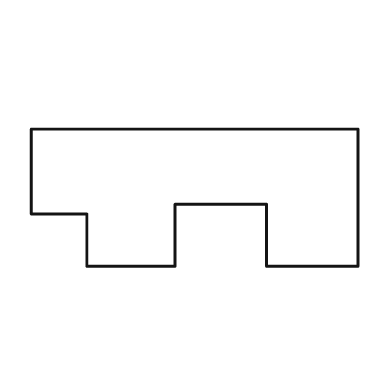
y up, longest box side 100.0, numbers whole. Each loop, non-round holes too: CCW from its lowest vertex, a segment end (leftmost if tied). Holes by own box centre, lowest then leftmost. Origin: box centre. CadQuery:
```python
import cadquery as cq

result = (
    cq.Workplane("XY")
    .moveTo(-33.0, -21.0)
    .lineTo(-6.0, -21.0)
    .lineTo(-6.0, -2.0)
    .lineTo(22.0, -2.0)
    .lineTo(22.0, -21.0)
    .lineTo(50.0, -21.0)
    .lineTo(50.0, 21.0)
    .lineTo(-50.0, 21.0)
    .lineTo(-50.0, -5.0)
    .lineTo(-33.0, -5.0)
    .close()
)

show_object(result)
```